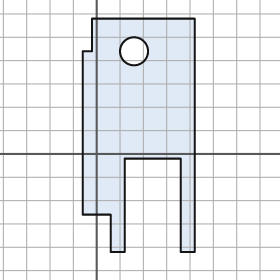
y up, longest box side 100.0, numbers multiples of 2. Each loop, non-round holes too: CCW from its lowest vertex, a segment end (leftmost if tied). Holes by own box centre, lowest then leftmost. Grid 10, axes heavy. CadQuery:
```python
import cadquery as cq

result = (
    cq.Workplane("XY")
    .moveTo(6.0, -42.0)
    .lineTo(12.0, -42.0)
    .lineTo(12.0, -2.0)
    .lineTo(36.0, -2.0)
    .lineTo(36.0, -42.0)
    .lineTo(42.0, -42.0)
    .lineTo(42.0, 58.0)
    .lineTo(-2.0, 58.0)
    .lineTo(-2.0, 44.0)
    .lineTo(-6.0, 44.0)
    .lineTo(-6.0, -26.0)
    .lineTo(6.0, -26.0)
    .close()
    .moveTo(16.0, 44.0)
    .circle(6.0)
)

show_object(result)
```